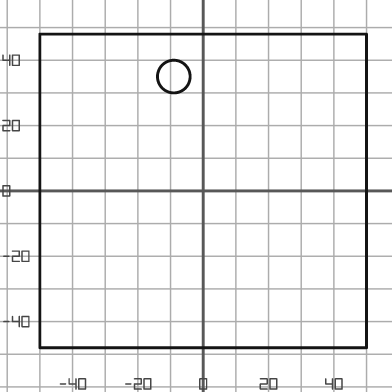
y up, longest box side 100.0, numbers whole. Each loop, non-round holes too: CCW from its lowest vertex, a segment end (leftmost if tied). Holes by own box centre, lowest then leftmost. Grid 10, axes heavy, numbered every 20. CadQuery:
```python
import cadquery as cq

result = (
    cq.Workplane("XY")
    .moveTo(-50.0, -48.0)
    .lineTo(50.0, -48.0)
    .lineTo(50.0, 48.0)
    .lineTo(-50.0, 48.0)
    .close()
    .moveTo(-9.0, 35.0)
    .circle(5.0)
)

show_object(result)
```